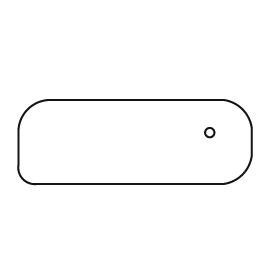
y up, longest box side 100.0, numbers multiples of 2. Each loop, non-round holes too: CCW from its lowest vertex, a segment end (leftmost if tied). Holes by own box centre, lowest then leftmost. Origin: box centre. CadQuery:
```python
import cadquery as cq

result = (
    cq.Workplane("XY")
    .moveTo(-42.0, -18.0)
    .lineTo(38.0, -18.0)
    .threePointArc((46.0, -14.0), (50.0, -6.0))
    .lineTo(50.0, 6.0)
    .threePointArc((46.0, 14.0), (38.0, 18.0))
    .lineTo(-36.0, 18.0)
    .threePointArc((-46.0, 14.0), (-50.0, 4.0))
    .lineTo(-50.0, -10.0)
    .threePointArc((-48.0, -16.0), (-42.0, -18.0))
    .close()
    .moveTo(32.0, 4.0)
    .circle(2.0)
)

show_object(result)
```